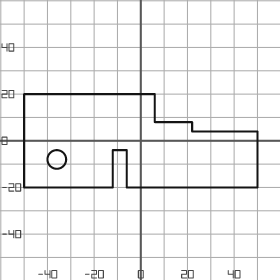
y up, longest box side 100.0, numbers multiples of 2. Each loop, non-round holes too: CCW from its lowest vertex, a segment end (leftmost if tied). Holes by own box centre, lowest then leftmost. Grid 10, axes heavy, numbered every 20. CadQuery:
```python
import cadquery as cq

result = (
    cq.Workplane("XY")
    .moveTo(-50.0, -20.0)
    .lineTo(-12.0, -20.0)
    .lineTo(-12.0, -4.0)
    .lineTo(-6.0, -4.0)
    .lineTo(-6.0, -20.0)
    .lineTo(50.0, -20.0)
    .lineTo(50.0, 4.0)
    .lineTo(22.0, 4.0)
    .lineTo(22.0, 8.0)
    .lineTo(6.0, 8.0)
    .lineTo(6.0, 20.0)
    .lineTo(-50.0, 20.0)
    .close()
    .moveTo(-36.0, -8.0)
    .circle(4.0)
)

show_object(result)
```